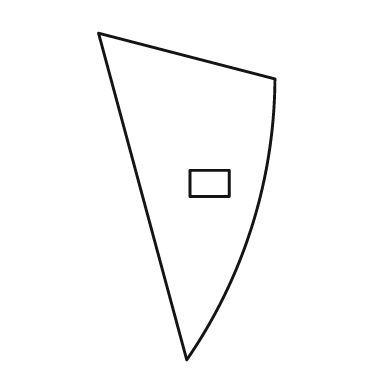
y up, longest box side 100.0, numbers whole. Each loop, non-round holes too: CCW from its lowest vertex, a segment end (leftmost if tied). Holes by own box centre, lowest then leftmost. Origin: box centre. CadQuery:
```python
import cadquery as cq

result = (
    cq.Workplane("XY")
    .moveTo(0.0, -50.0)
    .threePointArc((20.0, -9.0), (27.0, 36.0))
    .lineTo(-27.0, 50.0)
    .close()
    .moveTo(1.0, 0.0)
    .lineTo(13.0, 0.0)
    .lineTo(13.0, 8.0)
    .lineTo(1.0, 8.0)
    .close()
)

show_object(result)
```